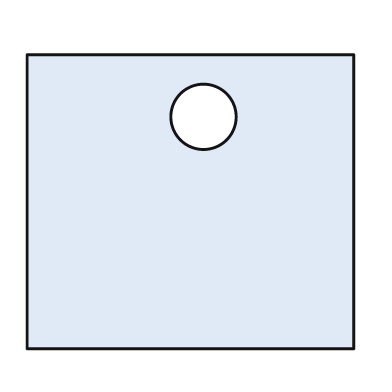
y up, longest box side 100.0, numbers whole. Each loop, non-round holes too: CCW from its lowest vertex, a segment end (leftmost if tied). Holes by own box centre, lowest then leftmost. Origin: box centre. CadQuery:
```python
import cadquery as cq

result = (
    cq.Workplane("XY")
    .moveTo(-50.0, -45.0)
    .lineTo(50.0, -45.0)
    .lineTo(50.0, 45.0)
    .lineTo(-50.0, 45.0)
    .close()
    .moveTo(4.0, 26.0)
    .circle(10.0)
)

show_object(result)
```